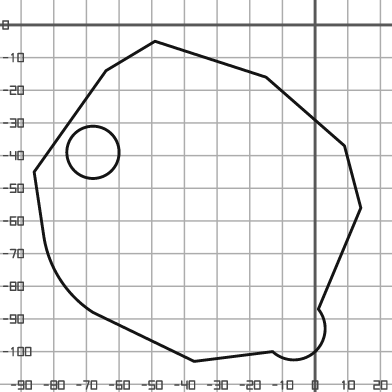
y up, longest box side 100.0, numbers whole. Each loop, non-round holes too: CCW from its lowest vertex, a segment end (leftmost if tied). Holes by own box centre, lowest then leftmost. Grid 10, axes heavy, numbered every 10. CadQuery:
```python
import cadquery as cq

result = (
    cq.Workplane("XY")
    .moveTo(-37.0, -103.0)
    .lineTo(-13.0, -100.0)
    .threePointArc((0.0, -100.0), (1.0, -87.0))
    .lineTo(14.0, -56.0)
    .lineTo(9.0, -37.0)
    .lineTo(-15.0, -16.0)
    .lineTo(-49.0, -5.0)
    .lineTo(-64.0, -14.0)
    .lineTo(-86.0, -45.0)
    .lineTo(-83.0, -65.0)
    .threePointArc((-78.0, -78.0), (-68.0, -88.0))
    .close()
    .moveTo(-68.0, -39.0)
    .circle(8.0)
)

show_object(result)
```